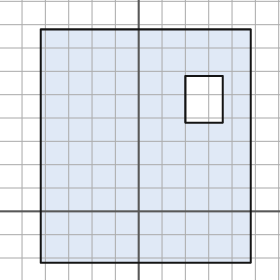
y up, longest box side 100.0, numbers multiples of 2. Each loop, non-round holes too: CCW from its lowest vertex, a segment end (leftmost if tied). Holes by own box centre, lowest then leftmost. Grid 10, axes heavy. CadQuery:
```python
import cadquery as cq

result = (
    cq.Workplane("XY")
    .moveTo(-42.0, -22.0)
    .lineTo(48.0, -22.0)
    .lineTo(48.0, 78.0)
    .lineTo(-42.0, 78.0)
    .close()
    .moveTo(20.0, 38.0)
    .lineTo(36.0, 38.0)
    .lineTo(36.0, 58.0)
    .lineTo(20.0, 58.0)
    .close()
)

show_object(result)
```